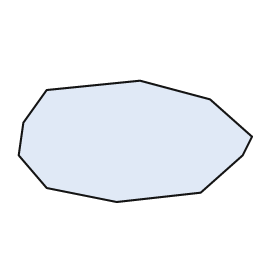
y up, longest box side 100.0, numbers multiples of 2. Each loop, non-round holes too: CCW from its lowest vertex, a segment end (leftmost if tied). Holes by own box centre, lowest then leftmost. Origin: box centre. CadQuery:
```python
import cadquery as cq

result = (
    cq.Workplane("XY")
    .moveTo(-8.0, -26.0)
    .lineTo(28.0, -22.0)
    .lineTo(46.0, -6.0)
    .lineTo(50.0, 2.0)
    .lineTo(32.0, 18.0)
    .lineTo(2.0, 26.0)
    .lineTo(-38.0, 22.0)
    .lineTo(-48.0, 8.0)
    .lineTo(-50.0, -6.0)
    .lineTo(-38.0, -20.0)
    .close()
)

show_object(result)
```